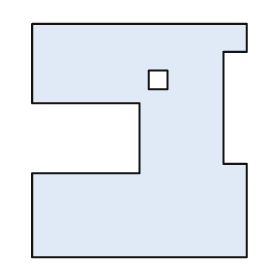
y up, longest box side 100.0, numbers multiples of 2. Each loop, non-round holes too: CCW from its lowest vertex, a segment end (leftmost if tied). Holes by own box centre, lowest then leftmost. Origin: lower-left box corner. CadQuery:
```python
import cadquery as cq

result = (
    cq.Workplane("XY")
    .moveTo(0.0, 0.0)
    .lineTo(92.0, 0.0)
    .lineTo(92.0, 40.0)
    .lineTo(82.0, 40.0)
    .lineTo(82.0, 88.0)
    .lineTo(92.0, 88.0)
    .lineTo(92.0, 100.0)
    .lineTo(0.0, 100.0)
    .lineTo(0.0, 66.0)
    .lineTo(46.0, 66.0)
    .lineTo(46.0, 36.0)
    .lineTo(0.0, 36.0)
    .close()
    .moveTo(50.0, 72.0)
    .lineTo(58.0, 72.0)
    .lineTo(58.0, 80.0)
    .lineTo(50.0, 80.0)
    .close()
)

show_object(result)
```